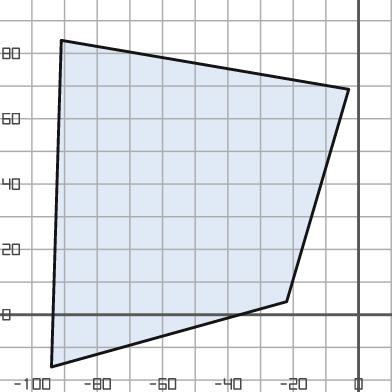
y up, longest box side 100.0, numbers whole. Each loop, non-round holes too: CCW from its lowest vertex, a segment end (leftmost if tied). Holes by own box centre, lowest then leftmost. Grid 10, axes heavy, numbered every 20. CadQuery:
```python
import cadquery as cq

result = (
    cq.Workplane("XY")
    .moveTo(-94.0, -16.0)
    .lineTo(-22.0, 4.0)
    .lineTo(-3.0, 69.0)
    .lineTo(-91.0, 84.0)
    .close()
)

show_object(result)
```